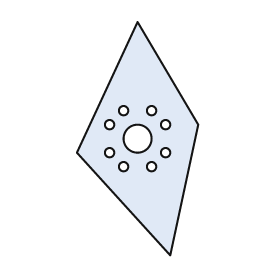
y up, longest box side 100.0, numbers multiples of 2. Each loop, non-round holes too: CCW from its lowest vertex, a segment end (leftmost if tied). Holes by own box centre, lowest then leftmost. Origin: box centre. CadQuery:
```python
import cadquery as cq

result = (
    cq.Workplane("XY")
    .moveTo(14.0, -50.0)
    .lineTo(26.0, 6.0)
    .lineTo(0.0, 50.0)
    .lineTo(-26.0, -6.0)
    .close()
    .moveTo(-6.0, -12.0)
    .circle(2.0)
    .moveTo(6.0, -12.0)
    .circle(2.0)
    .moveTo(-12.0, -6.0)
    .circle(2.0)
    .moveTo(12.0, -6.0)
    .circle(2.0)
    .moveTo(0.0, 0.0)
    .circle(6.0)
    .moveTo(-12.0, 6.0)
    .circle(2.0)
    .moveTo(12.0, 6.0)
    .circle(2.0)
    .moveTo(-6.0, 12.0)
    .circle(2.0)
    .moveTo(6.0, 12.0)
    .circle(2.0)
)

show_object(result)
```